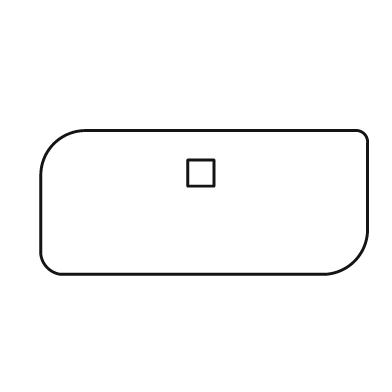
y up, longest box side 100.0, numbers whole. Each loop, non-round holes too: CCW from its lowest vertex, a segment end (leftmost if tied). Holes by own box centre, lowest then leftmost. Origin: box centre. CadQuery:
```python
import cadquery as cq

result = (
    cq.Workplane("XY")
    .moveTo(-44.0, -22.0)
    .lineTo(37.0, -22.0)
    .threePointArc((46.0, -18.0), (50.0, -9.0))
    .lineTo(50.0, 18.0)
    .threePointArc((49.0, 21.0), (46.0, 22.0))
    .lineTo(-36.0, 22.0)
    .threePointArc((-46.0, 18.0), (-50.0, 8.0))
    .lineTo(-50.0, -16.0)
    .threePointArc((-48.0, -20.0), (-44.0, -22.0))
    .close()
    .moveTo(-5.0, 5.0)
    .lineTo(3.0, 5.0)
    .lineTo(3.0, 13.0)
    .lineTo(-5.0, 13.0)
    .close()
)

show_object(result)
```